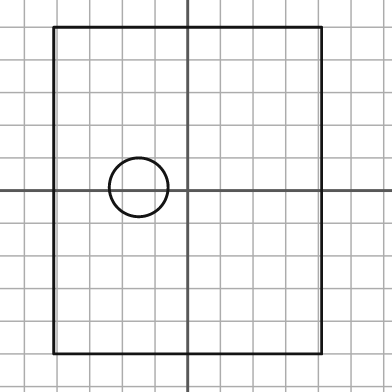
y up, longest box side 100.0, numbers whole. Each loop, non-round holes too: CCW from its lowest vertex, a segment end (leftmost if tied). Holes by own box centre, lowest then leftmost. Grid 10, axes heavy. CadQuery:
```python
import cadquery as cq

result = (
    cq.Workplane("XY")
    .moveTo(-41.0, -50.0)
    .lineTo(41.0, -50.0)
    .lineTo(41.0, 50.0)
    .lineTo(-41.0, 50.0)
    .close()
    .moveTo(-15.0, 1.0)
    .circle(9.0)
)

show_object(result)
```